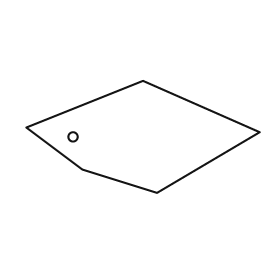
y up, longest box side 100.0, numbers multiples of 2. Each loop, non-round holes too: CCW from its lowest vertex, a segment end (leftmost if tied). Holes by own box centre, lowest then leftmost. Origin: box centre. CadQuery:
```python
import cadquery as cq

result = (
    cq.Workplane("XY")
    .moveTo(6.0, -24.0)
    .lineTo(50.0, 2.0)
    .lineTo(0.0, 24.0)
    .lineTo(-50.0, 4.0)
    .lineTo(-26.0, -14.0)
    .close()
    .moveTo(-30.0, 0.0)
    .circle(2.0)
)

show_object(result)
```